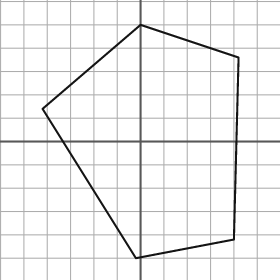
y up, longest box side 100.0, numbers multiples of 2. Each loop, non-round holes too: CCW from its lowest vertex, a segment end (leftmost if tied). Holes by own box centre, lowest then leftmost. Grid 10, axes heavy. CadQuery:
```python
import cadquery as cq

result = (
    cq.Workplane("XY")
    .moveTo(-2.0, -50.0)
    .lineTo(40.0, -42.0)
    .lineTo(42.0, 36.0)
    .lineTo(0.0, 50.0)
    .lineTo(-42.0, 14.0)
    .close()
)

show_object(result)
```